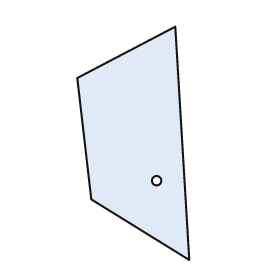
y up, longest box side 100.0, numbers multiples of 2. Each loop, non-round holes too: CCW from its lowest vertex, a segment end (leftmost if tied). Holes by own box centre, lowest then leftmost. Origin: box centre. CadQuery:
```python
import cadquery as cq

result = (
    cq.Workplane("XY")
    .moveTo(24.0, -50.0)
    .lineTo(18.0, 50.0)
    .lineTo(-24.0, 28.0)
    .lineTo(-18.0, -24.0)
    .close()
    .moveTo(10.0, -16.0)
    .circle(2.0)
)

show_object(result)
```